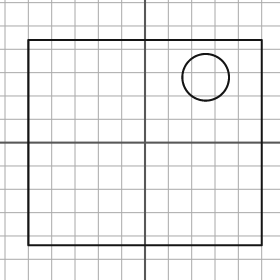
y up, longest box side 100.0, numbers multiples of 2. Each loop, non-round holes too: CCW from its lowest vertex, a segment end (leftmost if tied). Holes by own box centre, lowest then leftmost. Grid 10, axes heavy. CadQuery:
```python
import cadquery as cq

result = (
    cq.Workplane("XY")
    .moveTo(-50.0, -44.0)
    .lineTo(50.0, -44.0)
    .lineTo(50.0, 44.0)
    .lineTo(-50.0, 44.0)
    .close()
    .moveTo(26.0, 28.0)
    .circle(10.0)
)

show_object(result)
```